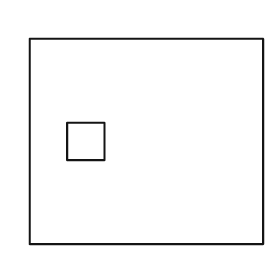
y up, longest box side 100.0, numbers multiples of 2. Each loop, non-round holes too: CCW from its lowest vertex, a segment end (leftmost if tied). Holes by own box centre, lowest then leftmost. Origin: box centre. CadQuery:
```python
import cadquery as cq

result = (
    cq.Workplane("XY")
    .moveTo(-50.0, -44.0)
    .lineTo(50.0, -44.0)
    .lineTo(50.0, 44.0)
    .lineTo(-50.0, 44.0)
    .close()
    .moveTo(-34.0, -8.0)
    .lineTo(-18.0, -8.0)
    .lineTo(-18.0, 8.0)
    .lineTo(-34.0, 8.0)
    .close()
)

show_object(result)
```